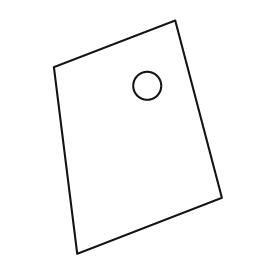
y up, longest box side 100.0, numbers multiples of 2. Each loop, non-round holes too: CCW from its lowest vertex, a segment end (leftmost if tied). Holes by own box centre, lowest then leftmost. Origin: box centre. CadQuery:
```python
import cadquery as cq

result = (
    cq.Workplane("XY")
    .moveTo(-26.0, -50.0)
    .lineTo(36.0, -26.0)
    .lineTo(16.0, 50.0)
    .lineTo(-36.0, 30.0)
    .close()
    .moveTo(4.0, 22.0)
    .circle(6.0)
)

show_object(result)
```